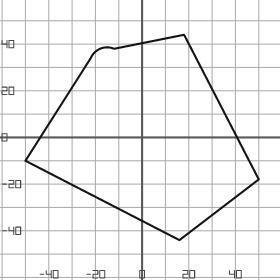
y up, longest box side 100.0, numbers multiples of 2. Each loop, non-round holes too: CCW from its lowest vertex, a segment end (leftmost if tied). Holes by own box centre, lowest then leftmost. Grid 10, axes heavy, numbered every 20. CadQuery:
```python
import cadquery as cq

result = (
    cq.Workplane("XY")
    .moveTo(16.0, -44.0)
    .lineTo(50.0, -18.0)
    .lineTo(18.0, 44.0)
    .lineTo(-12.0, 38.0)
    .threePointArc((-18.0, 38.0), (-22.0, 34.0))
    .lineTo(-50.0, -10.0)
    .close()
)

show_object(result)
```